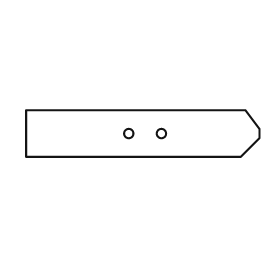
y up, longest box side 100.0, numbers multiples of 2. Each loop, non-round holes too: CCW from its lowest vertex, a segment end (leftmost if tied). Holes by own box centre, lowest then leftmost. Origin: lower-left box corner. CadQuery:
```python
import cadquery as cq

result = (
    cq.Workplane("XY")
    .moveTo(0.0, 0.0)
    .lineTo(92.0, 0.0)
    .lineTo(100.0, 8.0)
    .lineTo(100.0, 12.0)
    .lineTo(94.0, 20.0)
    .lineTo(0.0, 20.0)
    .close()
    .moveTo(44.0, 10.0)
    .circle(2.0)
    .moveTo(58.0, 10.0)
    .circle(2.0)
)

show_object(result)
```